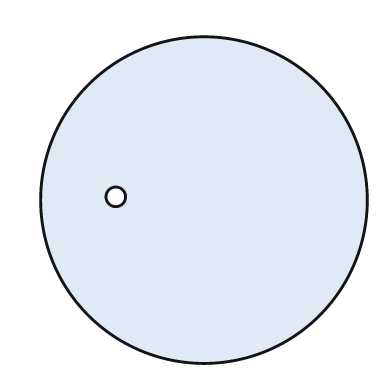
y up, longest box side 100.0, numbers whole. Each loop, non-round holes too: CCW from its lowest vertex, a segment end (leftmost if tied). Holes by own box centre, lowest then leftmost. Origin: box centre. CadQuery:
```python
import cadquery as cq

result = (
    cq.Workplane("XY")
    .moveTo(0.0, 0.0)
    .circle(50.0)
    .moveTo(-27.0, 1.0)
    .circle(3.0)
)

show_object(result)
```